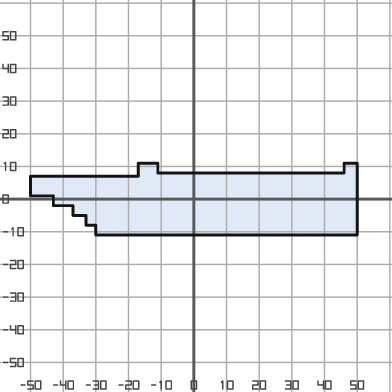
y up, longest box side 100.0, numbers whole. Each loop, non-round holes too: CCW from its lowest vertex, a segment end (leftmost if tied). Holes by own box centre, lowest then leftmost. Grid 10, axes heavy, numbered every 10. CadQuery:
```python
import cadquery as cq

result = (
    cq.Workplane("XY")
    .moveTo(-30.0, -11.0)
    .lineTo(50.0, -11.0)
    .lineTo(50.0, 11.0)
    .lineTo(46.0, 11.0)
    .lineTo(46.0, 8.0)
    .lineTo(-11.0, 8.0)
    .lineTo(-11.0, 11.0)
    .lineTo(-17.0, 11.0)
    .lineTo(-17.0, 7.0)
    .lineTo(-50.0, 7.0)
    .lineTo(-50.0, 1.0)
    .lineTo(-43.0, 1.0)
    .lineTo(-43.0, -2.0)
    .lineTo(-37.0, -2.0)
    .lineTo(-37.0, -5.0)
    .lineTo(-33.0, -5.0)
    .lineTo(-33.0, -8.0)
    .lineTo(-30.0, -8.0)
    .close()
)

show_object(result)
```